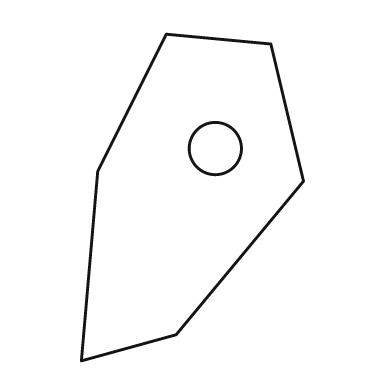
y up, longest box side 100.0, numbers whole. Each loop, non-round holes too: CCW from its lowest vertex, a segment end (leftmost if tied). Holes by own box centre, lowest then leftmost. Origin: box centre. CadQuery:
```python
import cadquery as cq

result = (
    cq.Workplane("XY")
    .moveTo(-34.0, -50.0)
    .lineTo(-5.0, -42.0)
    .lineTo(34.0, 5.0)
    .lineTo(24.0, 47.0)
    .lineTo(-8.0, 50.0)
    .lineTo(-29.0, 8.0)
    .close()
    .moveTo(7.0, 15.0)
    .circle(8.0)
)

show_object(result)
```